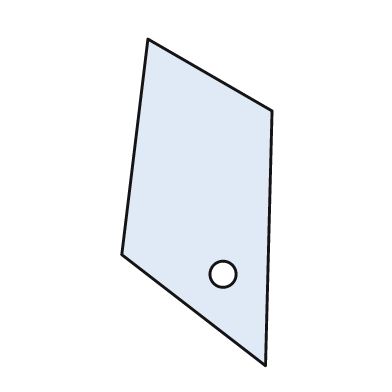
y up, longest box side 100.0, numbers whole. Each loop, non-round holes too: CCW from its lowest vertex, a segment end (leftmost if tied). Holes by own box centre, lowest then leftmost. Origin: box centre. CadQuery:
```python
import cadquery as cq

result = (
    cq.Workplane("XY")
    .moveTo(21.0, -50.0)
    .lineTo(23.0, 28.0)
    .lineTo(-15.0, 50.0)
    .lineTo(-23.0, -16.0)
    .close()
    .moveTo(8.0, -22.0)
    .circle(4.0)
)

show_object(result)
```